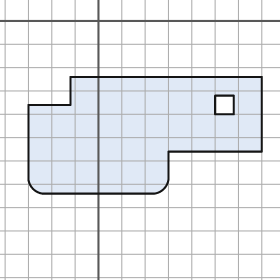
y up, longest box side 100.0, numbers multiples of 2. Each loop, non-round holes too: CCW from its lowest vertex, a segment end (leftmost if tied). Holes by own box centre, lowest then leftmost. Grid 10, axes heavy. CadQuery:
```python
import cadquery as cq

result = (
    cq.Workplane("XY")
    .moveTo(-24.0, -74.0)
    .lineTo(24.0, -74.0)
    .threePointArc((28.0, -72.0), (30.0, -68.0))
    .lineTo(30.0, -56.0)
    .lineTo(70.0, -56.0)
    .lineTo(70.0, -24.0)
    .lineTo(-12.0, -24.0)
    .lineTo(-12.0, -36.0)
    .lineTo(-30.0, -36.0)
    .lineTo(-30.0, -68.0)
    .threePointArc((-28.0, -72.0), (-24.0, -74.0))
    .close()
    .moveTo(50.0, -40.0)
    .lineTo(58.0, -40.0)
    .lineTo(58.0, -32.0)
    .lineTo(50.0, -32.0)
    .close()
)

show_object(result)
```